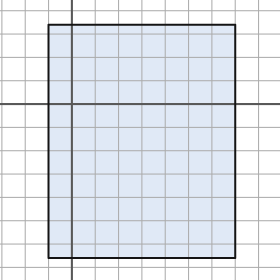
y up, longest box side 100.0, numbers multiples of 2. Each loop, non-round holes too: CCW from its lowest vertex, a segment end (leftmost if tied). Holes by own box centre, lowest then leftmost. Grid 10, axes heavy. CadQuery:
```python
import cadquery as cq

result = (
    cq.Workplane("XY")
    .moveTo(-10.0, -66.0)
    .lineTo(70.0, -66.0)
    .lineTo(70.0, 34.0)
    .lineTo(-10.0, 34.0)
    .close()
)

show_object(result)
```